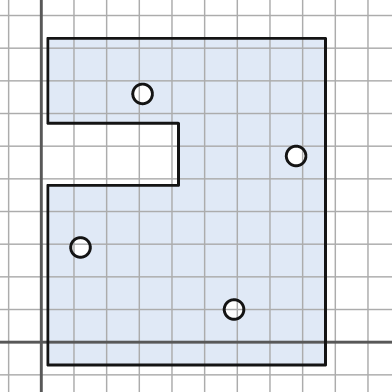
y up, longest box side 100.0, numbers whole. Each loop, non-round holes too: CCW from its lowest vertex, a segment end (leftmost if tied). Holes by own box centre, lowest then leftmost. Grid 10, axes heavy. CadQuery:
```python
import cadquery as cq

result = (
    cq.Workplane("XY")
    .moveTo(2.0, -7.0)
    .lineTo(87.0, -7.0)
    .lineTo(87.0, 93.0)
    .lineTo(2.0, 93.0)
    .lineTo(2.0, 67.0)
    .lineTo(42.0, 67.0)
    .lineTo(42.0, 48.0)
    .lineTo(2.0, 48.0)
    .close()
    .moveTo(59.0, 10.0)
    .circle(3.0)
    .moveTo(12.0, 29.0)
    .circle(3.0)
    .moveTo(78.0, 57.0)
    .circle(3.0)
    .moveTo(31.0, 76.0)
    .circle(3.0)
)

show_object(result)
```